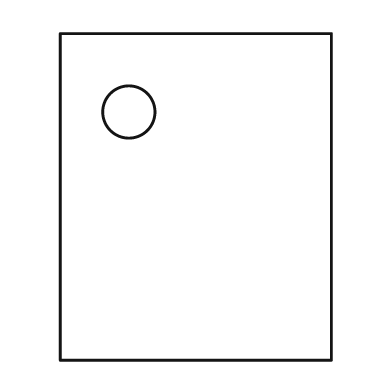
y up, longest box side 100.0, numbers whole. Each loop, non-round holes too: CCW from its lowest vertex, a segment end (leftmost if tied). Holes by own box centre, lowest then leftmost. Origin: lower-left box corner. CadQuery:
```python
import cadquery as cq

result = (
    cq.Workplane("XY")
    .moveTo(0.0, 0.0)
    .lineTo(83.0, 0.0)
    .lineTo(83.0, 100.0)
    .lineTo(0.0, 100.0)
    .close()
    .moveTo(21.0, 76.0)
    .circle(8.0)
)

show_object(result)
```